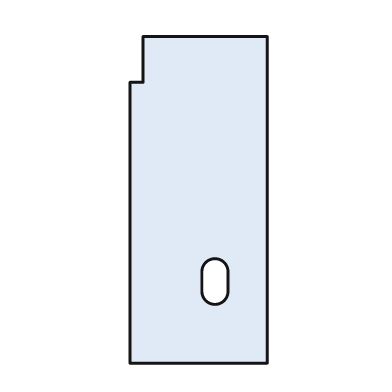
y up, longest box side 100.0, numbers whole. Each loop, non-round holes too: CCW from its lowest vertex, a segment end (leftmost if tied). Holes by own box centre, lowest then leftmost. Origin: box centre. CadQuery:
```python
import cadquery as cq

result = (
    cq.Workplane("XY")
    .moveTo(-21.0, -50.0)
    .lineTo(21.0, -50.0)
    .lineTo(21.0, 50.0)
    .lineTo(-17.0, 50.0)
    .lineTo(-17.0, 36.0)
    .lineTo(-21.0, 36.0)
    .close()
    .moveTo(1.0, -28.0)
    .threePointArc((5.0, -32.0), (9.0, -28.0))
    .lineTo(9.0, -22.0)
    .threePointArc((5.0, -18.0), (1.0, -22.0))
    .close()
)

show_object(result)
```